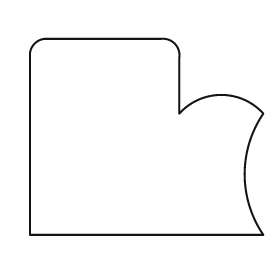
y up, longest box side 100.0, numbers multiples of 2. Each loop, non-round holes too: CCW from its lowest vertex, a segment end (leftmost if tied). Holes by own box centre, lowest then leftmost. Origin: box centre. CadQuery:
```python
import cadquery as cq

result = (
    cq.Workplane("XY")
    .moveTo(-50.0, -42.0)
    .lineTo(50.0, -42.0)
    .threePointArc((42.0, -16.0), (50.0, 10.0))
    .threePointArc((32.0, 18.0), (14.0, 10.0))
    .lineTo(14.0, 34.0)
    .threePointArc((12.0, 40.0), (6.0, 42.0))
    .lineTo(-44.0, 42.0)
    .threePointArc((-48.0, 40.0), (-50.0, 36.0))
    .close()
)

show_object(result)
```